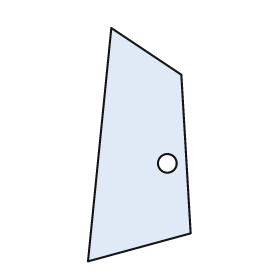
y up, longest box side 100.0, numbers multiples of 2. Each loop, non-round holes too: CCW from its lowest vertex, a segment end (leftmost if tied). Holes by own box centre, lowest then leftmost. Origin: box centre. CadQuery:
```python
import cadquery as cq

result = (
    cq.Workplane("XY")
    .moveTo(-22.0, -50.0)
    .lineTo(22.0, -38.0)
    .lineTo(18.0, 30.0)
    .lineTo(-12.0, 50.0)
    .close()
    .moveTo(12.0, -8.0)
    .circle(4.0)
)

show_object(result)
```